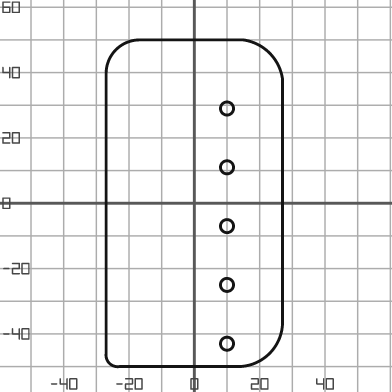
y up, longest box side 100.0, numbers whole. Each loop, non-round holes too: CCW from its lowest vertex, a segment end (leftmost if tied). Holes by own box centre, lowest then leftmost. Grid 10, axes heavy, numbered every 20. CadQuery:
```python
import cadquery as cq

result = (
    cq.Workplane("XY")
    .moveTo(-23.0, -50.0)
    .lineTo(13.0, -50.0)
    .threePointArc((23.0, -46.0), (27.0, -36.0))
    .lineTo(27.0, 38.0)
    .threePointArc((23.0, 46.0), (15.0, 50.0))
    .lineTo(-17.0, 50.0)
    .threePointArc((-24.0, 47.0), (-27.0, 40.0))
    .lineTo(-27.0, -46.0)
    .threePointArc((-26.0, -49.0), (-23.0, -50.0))
    .close()
    .moveTo(10.0, -43.0)
    .circle(2.0)
    .moveTo(10.0, -25.0)
    .circle(2.0)
    .moveTo(10.0, -7.0)
    .circle(2.0)
    .moveTo(10.0, 11.0)
    .circle(2.0)
    .moveTo(10.0, 29.0)
    .circle(2.0)
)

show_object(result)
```